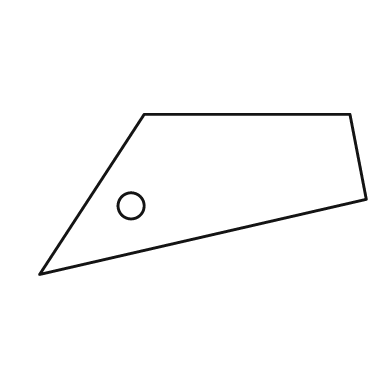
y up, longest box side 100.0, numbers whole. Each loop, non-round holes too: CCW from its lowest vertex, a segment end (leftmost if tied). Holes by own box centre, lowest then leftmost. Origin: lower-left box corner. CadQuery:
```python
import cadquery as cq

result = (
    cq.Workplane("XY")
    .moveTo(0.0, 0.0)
    .lineTo(100.0, 23.0)
    .lineTo(95.0, 49.0)
    .lineTo(32.0, 49.0)
    .close()
    .moveTo(28.0, 21.0)
    .circle(4.0)
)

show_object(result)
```